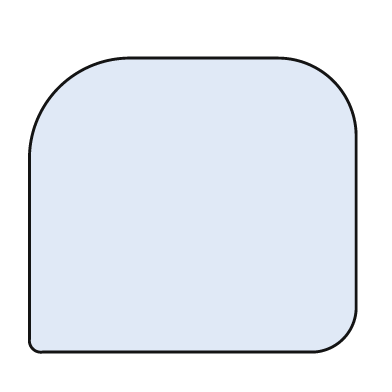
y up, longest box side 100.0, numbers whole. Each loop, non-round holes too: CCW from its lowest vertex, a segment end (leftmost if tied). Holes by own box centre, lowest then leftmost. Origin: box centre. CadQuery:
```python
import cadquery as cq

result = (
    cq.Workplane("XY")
    .moveTo(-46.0, -45.0)
    .lineTo(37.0, -45.0)
    .threePointArc((46.0, -41.0), (50.0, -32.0))
    .lineTo(50.0, 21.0)
    .threePointArc((43.0, 38.0), (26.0, 45.0))
    .lineTo(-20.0, 45.0)
    .threePointArc((-41.0, 36.0), (-50.0, 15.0))
    .lineTo(-50.0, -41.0)
    .threePointArc((-49.0, -44.0), (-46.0, -45.0))
    .close()
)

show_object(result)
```